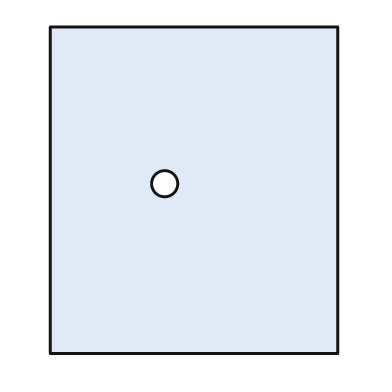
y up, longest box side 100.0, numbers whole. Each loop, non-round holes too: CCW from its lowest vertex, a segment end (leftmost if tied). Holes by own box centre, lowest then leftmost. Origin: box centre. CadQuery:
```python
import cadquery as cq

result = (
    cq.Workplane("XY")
    .moveTo(-44.0, -50.0)
    .lineTo(44.0, -50.0)
    .lineTo(44.0, 50.0)
    .lineTo(-44.0, 50.0)
    .close()
    .moveTo(-9.0, 2.0)
    .circle(4.0)
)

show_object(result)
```